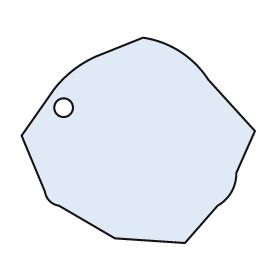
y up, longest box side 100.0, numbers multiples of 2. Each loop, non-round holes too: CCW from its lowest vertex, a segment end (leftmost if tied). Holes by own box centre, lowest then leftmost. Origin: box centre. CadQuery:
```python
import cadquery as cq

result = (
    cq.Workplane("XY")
    .moveTo(20.0, -44.0)
    .lineTo(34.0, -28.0)
    .threePointArc((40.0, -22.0), (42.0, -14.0))
    .lineTo(50.0, 4.0)
    .lineTo(30.0, 26.0)
    .threePointArc((18.0, 38.0), (2.0, 44.0))
    .lineTo(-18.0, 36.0)
    .threePointArc((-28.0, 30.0), (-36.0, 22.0))
    .lineTo(-50.0, 2.0)
    .lineTo(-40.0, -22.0)
    .threePointArc((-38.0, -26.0), (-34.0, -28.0))
    .lineTo(-10.0, -42.0)
    .close()
    .moveTo(-32.0, 14.0)
    .circle(4.0)
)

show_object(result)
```